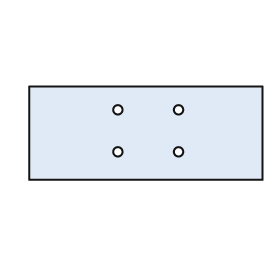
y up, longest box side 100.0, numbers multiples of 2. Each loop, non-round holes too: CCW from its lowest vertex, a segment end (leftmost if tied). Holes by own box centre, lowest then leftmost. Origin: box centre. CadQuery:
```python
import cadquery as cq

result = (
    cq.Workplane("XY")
    .moveTo(-50.0, -20.0)
    .lineTo(50.0, -20.0)
    .lineTo(50.0, 20.0)
    .lineTo(-50.0, 20.0)
    .close()
    .moveTo(-12.0, -8.0)
    .circle(2.0)
    .moveTo(14.0, -8.0)
    .circle(2.0)
    .moveTo(-12.0, 10.0)
    .circle(2.0)
    .moveTo(14.0, 10.0)
    .circle(2.0)
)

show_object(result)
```